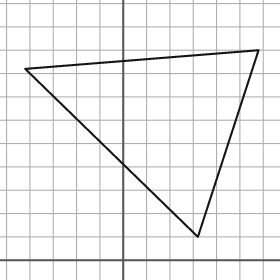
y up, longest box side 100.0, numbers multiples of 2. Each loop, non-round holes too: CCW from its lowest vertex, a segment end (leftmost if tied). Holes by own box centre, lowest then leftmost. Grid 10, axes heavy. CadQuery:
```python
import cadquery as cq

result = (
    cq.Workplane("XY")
    .moveTo(32.0, 10.0)
    .lineTo(58.0, 90.0)
    .lineTo(-42.0, 82.0)
    .close()
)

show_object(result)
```